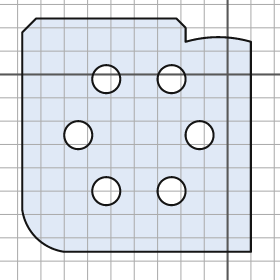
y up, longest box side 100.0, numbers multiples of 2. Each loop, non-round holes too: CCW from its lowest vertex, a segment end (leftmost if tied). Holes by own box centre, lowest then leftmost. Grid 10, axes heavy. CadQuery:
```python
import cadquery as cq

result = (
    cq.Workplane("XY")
    .moveTo(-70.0, -76.0)
    .lineTo(10.0, -76.0)
    .lineTo(10.0, 14.0)
    .threePointArc((-4.0, 16.0), (-18.0, 14.0))
    .lineTo(-18.0, 20.0)
    .lineTo(-22.0, 24.0)
    .lineTo(-82.0, 24.0)
    .lineTo(-88.0, 18.0)
    .lineTo(-88.0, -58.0)
    .threePointArc((-82.0, -70.0), (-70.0, -76.0))
    .close()
    .moveTo(-52.0, -50.0)
    .circle(6.0)
    .moveTo(-24.0, -50.0)
    .circle(6.0)
    .moveTo(-64.0, -26.0)
    .circle(6.0)
    .moveTo(-12.0, -26.0)
    .circle(6.0)
    .moveTo(-52.0, -2.0)
    .circle(6.0)
    .moveTo(-24.0, -2.0)
    .circle(6.0)
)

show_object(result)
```